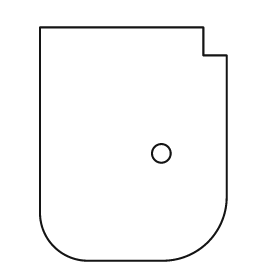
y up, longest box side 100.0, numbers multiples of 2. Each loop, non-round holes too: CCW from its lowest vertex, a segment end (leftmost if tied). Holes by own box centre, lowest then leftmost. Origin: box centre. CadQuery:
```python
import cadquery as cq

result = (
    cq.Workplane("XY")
    .moveTo(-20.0, -50.0)
    .lineTo(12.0, -50.0)
    .threePointArc((32.0, -42.0), (40.0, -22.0))
    .lineTo(40.0, 38.0)
    .lineTo(30.0, 38.0)
    .lineTo(30.0, 50.0)
    .lineTo(-40.0, 50.0)
    .lineTo(-40.0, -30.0)
    .threePointArc((-34.0, -44.0), (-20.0, -50.0))
    .close()
    .moveTo(12.0, -4.0)
    .circle(4.0)
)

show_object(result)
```